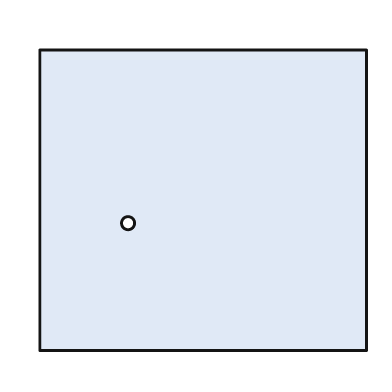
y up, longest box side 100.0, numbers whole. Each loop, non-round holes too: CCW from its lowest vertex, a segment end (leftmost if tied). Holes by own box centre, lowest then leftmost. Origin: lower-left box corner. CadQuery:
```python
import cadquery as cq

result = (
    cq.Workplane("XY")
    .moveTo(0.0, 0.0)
    .lineTo(100.0, 0.0)
    .lineTo(100.0, 92.0)
    .lineTo(0.0, 92.0)
    .close()
    .moveTo(27.0, 39.0)
    .circle(2.0)
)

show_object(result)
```